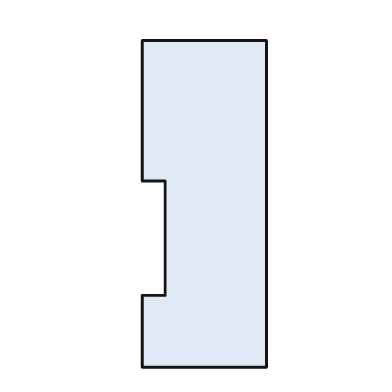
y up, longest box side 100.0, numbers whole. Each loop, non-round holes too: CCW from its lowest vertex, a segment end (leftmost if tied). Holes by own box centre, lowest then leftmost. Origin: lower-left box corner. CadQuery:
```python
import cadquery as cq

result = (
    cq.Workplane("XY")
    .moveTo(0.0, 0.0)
    .lineTo(38.0, 0.0)
    .lineTo(38.0, 100.0)
    .lineTo(0.0, 100.0)
    .lineTo(0.0, 57.0)
    .lineTo(7.0, 57.0)
    .lineTo(7.0, 22.0)
    .lineTo(0.0, 22.0)
    .close()
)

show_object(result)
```